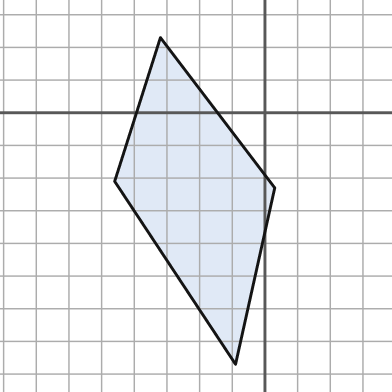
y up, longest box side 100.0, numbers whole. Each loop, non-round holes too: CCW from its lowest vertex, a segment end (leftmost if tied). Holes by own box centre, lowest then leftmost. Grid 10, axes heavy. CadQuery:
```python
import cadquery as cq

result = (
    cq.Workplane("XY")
    .moveTo(-9.0, -77.0)
    .lineTo(3.0, -23.0)
    .lineTo(-32.0, 23.0)
    .lineTo(-46.0, -21.0)
    .close()
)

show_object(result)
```